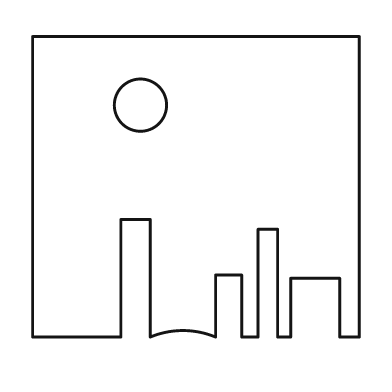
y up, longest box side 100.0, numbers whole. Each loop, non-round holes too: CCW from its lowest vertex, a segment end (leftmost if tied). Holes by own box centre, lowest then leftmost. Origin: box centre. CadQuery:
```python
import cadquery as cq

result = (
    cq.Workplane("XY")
    .moveTo(-50.0, -46.0)
    .lineTo(-23.0, -46.0)
    .lineTo(-23.0, -10.0)
    .lineTo(-14.0, -10.0)
    .lineTo(-14.0, -46.0)
    .threePointArc((-4.0, -44.0), (6.0, -46.0))
    .lineTo(6.0, -27.0)
    .lineTo(14.0, -27.0)
    .lineTo(14.0, -46.0)
    .lineTo(19.0, -46.0)
    .lineTo(19.0, -13.0)
    .lineTo(25.0, -13.0)
    .lineTo(25.0, -46.0)
    .lineTo(29.0, -46.0)
    .lineTo(29.0, -28.0)
    .lineTo(44.0, -28.0)
    .lineTo(44.0, -46.0)
    .lineTo(50.0, -46.0)
    .lineTo(50.0, 46.0)
    .lineTo(-50.0, 46.0)
    .close()
    .moveTo(-17.0, 25.0)
    .circle(8.0)
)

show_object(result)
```